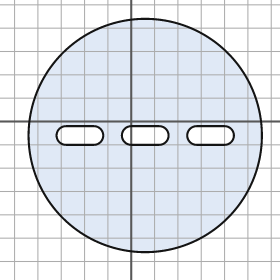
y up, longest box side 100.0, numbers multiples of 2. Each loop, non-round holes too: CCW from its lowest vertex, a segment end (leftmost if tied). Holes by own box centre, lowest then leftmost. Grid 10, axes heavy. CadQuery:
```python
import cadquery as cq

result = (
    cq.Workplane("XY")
    .moveTo(6.0, -6.0)
    .circle(50.0)
    .moveTo(-28.0, -10.0)
    .lineTo(-16.0, -10.0)
    .threePointArc((-12.0, -6.0), (-16.0, -2.0))
    .lineTo(-28.0, -2.0)
    .threePointArc((-32.0, -6.0), (-28.0, -10.0))
    .close()
    .moveTo(0.0, -10.0)
    .lineTo(12.0, -10.0)
    .threePointArc((16.0, -6.0), (12.0, -2.0))
    .lineTo(0.0, -2.0)
    .threePointArc((-4.0, -6.0), (0.0, -10.0))
    .close()
    .moveTo(28.0, -10.0)
    .lineTo(40.0, -10.0)
    .threePointArc((44.0, -6.0), (40.0, -2.0))
    .lineTo(28.0, -2.0)
    .threePointArc((24.0, -6.0), (28.0, -10.0))
    .close()
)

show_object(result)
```